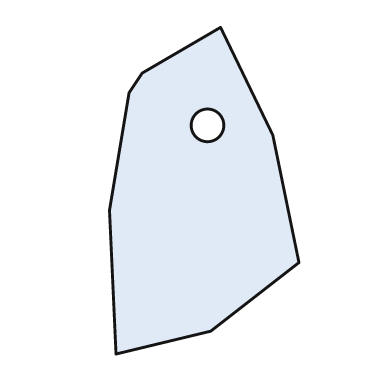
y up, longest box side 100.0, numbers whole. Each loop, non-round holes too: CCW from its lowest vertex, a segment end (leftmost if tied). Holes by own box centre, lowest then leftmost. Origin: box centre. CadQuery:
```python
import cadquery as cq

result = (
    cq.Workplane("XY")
    .moveTo(-27.0, -50.0)
    .lineTo(2.0, -43.0)
    .lineTo(29.0, -22.0)
    .lineTo(21.0, 17.0)
    .lineTo(5.0, 50.0)
    .lineTo(-19.0, 36.0)
    .lineTo(-23.0, 30.0)
    .lineTo(-29.0, -6.0)
    .close()
    .moveTo(1.0, 20.0)
    .circle(5.0)
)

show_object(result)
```